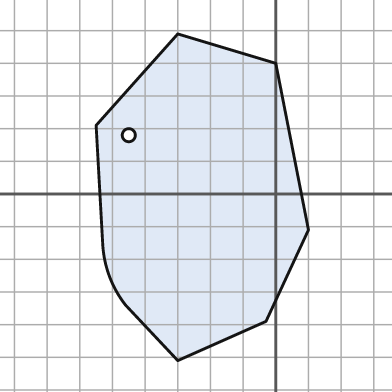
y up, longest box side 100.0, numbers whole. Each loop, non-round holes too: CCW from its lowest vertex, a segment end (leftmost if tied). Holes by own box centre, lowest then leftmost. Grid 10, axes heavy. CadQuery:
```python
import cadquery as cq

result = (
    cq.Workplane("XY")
    .moveTo(-30.0, -51.0)
    .lineTo(-3.0, -39.0)
    .lineTo(10.0, -11.0)
    .lineTo(0.0, 40.0)
    .lineTo(-30.0, 49.0)
    .lineTo(-55.0, 21.0)
    .lineTo(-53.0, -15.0)
    .threePointArc((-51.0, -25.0), (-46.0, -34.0))
    .close()
    .moveTo(-45.0, 18.0)
    .circle(2.0)
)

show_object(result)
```